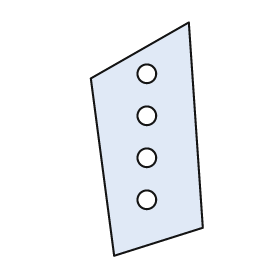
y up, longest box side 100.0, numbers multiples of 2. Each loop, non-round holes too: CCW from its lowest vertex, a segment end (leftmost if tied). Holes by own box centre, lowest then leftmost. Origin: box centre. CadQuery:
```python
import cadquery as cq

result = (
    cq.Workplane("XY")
    .moveTo(-14.0, -50.0)
    .lineTo(24.0, -38.0)
    .lineTo(18.0, 50.0)
    .lineTo(-24.0, 26.0)
    .close()
    .moveTo(0.0, -26.0)
    .circle(4.0)
    .moveTo(0.0, -8.0)
    .circle(4.0)
    .moveTo(0.0, 10.0)
    .circle(4.0)
    .moveTo(0.0, 28.0)
    .circle(4.0)
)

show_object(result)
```